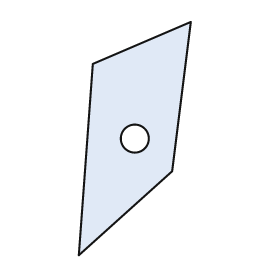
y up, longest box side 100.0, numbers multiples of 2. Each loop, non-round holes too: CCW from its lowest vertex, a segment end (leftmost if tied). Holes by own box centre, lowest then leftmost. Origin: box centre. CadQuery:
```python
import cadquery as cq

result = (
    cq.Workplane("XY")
    .moveTo(-24.0, -50.0)
    .lineTo(16.0, -14.0)
    .lineTo(24.0, 50.0)
    .lineTo(-18.0, 32.0)
    .close()
    .moveTo(0.0, 0.0)
    .circle(6.0)
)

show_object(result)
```